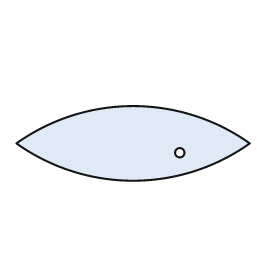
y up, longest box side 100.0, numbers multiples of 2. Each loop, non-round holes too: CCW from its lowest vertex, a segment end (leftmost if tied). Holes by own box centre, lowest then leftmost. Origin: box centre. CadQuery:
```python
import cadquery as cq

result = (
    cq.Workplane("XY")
    .moveTo(-50.0, 0.0)
    .threePointArc((0.0, -16.0), (50.0, 0.0))
    .threePointArc((0.0, 16.0), (-50.0, 0.0))
    .close()
    .moveTo(20.0, -4.0)
    .circle(2.0)
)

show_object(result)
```